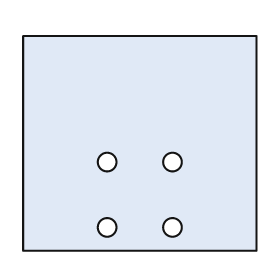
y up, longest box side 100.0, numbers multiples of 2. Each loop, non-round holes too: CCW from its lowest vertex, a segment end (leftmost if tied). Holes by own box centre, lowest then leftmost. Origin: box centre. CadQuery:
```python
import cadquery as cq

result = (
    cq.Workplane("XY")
    .moveTo(-50.0, -46.0)
    .lineTo(50.0, -46.0)
    .lineTo(50.0, 46.0)
    .lineTo(-50.0, 46.0)
    .close()
    .moveTo(-14.0, -36.0)
    .circle(4.0)
    .moveTo(14.0, -36.0)
    .circle(4.0)
    .moveTo(-14.0, -8.0)
    .circle(4.0)
    .moveTo(14.0, -8.0)
    .circle(4.0)
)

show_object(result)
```